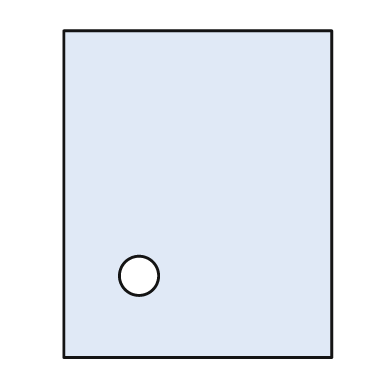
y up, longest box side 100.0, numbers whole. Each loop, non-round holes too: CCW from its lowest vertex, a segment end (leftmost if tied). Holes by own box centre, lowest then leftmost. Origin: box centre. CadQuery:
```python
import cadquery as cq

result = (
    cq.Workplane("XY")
    .moveTo(-41.0, -50.0)
    .lineTo(41.0, -50.0)
    .lineTo(41.0, 50.0)
    .lineTo(-41.0, 50.0)
    .close()
    .moveTo(-18.0, -25.0)
    .circle(6.0)
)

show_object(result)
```